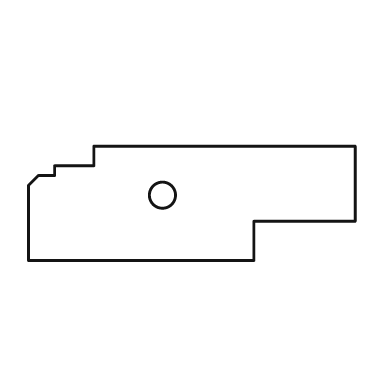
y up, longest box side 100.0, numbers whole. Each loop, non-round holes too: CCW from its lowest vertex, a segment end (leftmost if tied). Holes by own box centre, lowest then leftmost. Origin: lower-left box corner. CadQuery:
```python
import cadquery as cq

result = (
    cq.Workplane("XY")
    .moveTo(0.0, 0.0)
    .lineTo(69.0, 0.0)
    .lineTo(69.0, 12.0)
    .lineTo(100.0, 12.0)
    .lineTo(100.0, 35.0)
    .lineTo(20.0, 35.0)
    .lineTo(20.0, 29.0)
    .lineTo(8.0, 29.0)
    .lineTo(8.0, 26.0)
    .lineTo(3.0, 26.0)
    .lineTo(0.0, 23.0)
    .close()
    .moveTo(41.0, 20.0)
    .circle(4.0)
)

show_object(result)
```